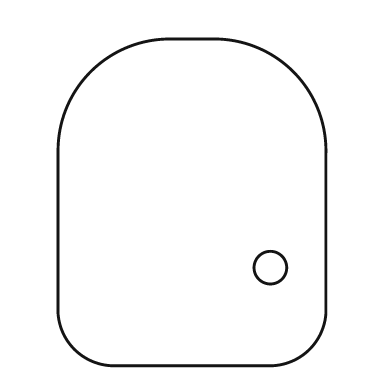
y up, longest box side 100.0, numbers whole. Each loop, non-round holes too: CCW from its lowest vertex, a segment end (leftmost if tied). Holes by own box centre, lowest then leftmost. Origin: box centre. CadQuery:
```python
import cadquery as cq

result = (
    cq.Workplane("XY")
    .moveTo(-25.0, -50.0)
    .lineTo(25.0, -50.0)
    .threePointArc((36.0, -45.0), (41.0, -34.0))
    .lineTo(41.0, 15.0)
    .threePointArc((31.0, 40.0), (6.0, 50.0))
    .lineTo(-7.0, 50.0)
    .threePointArc((-31.0, 40.0), (-41.0, 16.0))
    .lineTo(-41.0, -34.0)
    .threePointArc((-36.0, -45.0), (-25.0, -50.0))
    .close()
    .moveTo(24.0, -20.0)
    .circle(5.0)
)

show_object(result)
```